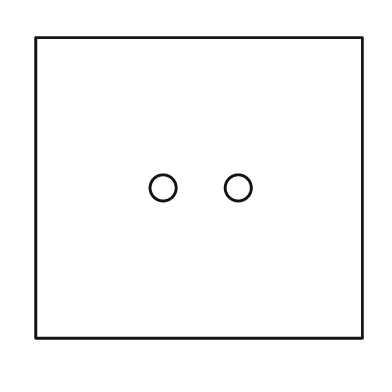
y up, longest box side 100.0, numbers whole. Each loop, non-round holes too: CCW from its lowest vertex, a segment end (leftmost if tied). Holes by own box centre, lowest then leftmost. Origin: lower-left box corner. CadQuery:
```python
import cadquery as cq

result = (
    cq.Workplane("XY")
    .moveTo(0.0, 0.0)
    .lineTo(100.0, 0.0)
    .lineTo(100.0, 92.0)
    .lineTo(0.0, 92.0)
    .close()
    .moveTo(39.0, 46.0)
    .circle(4.0)
    .moveTo(62.0, 46.0)
    .circle(4.0)
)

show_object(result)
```